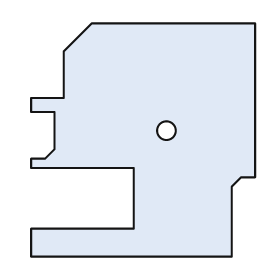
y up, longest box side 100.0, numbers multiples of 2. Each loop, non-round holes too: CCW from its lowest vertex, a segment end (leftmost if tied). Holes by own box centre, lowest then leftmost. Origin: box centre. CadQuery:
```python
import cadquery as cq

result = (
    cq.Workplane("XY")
    .moveTo(-48.0, -50.0)
    .lineTo(38.0, -50.0)
    .lineTo(38.0, -20.0)
    .lineTo(42.0, -16.0)
    .lineTo(48.0, -16.0)
    .lineTo(48.0, 50.0)
    .lineTo(-22.0, 50.0)
    .lineTo(-34.0, 38.0)
    .lineTo(-34.0, 18.0)
    .lineTo(-48.0, 18.0)
    .lineTo(-48.0, 12.0)
    .lineTo(-38.0, 12.0)
    .lineTo(-38.0, -4.0)
    .lineTo(-42.0, -8.0)
    .lineTo(-48.0, -8.0)
    .lineTo(-48.0, -12.0)
    .lineTo(-4.0, -12.0)
    .lineTo(-4.0, -38.0)
    .lineTo(-48.0, -38.0)
    .close()
    .moveTo(10.0, 4.0)
    .circle(4.0)
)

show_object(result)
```